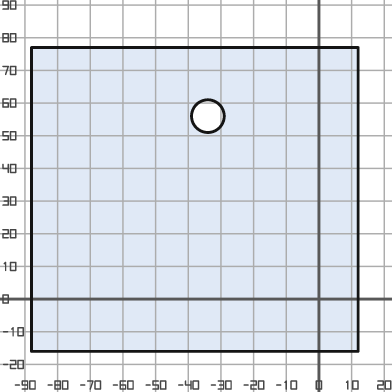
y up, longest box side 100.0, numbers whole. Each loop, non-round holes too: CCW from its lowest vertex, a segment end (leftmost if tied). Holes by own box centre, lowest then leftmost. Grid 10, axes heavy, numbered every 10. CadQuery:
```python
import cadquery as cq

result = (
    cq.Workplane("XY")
    .moveTo(-88.0, -16.0)
    .lineTo(12.0, -16.0)
    .lineTo(12.0, 77.0)
    .lineTo(-88.0, 77.0)
    .close()
    .moveTo(-34.0, 56.0)
    .circle(5.0)
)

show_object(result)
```